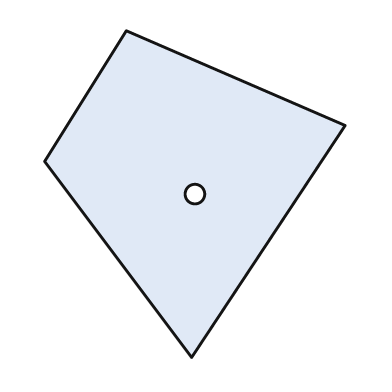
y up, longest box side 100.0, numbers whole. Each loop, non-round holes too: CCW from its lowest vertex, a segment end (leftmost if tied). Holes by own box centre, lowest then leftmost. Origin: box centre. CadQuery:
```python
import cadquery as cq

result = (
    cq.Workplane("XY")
    .moveTo(-1.0, -50.0)
    .lineTo(46.0, 21.0)
    .lineTo(-21.0, 50.0)
    .lineTo(-46.0, 10.0)
    .close()
    .moveTo(0.0, 0.0)
    .circle(3.0)
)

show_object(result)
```